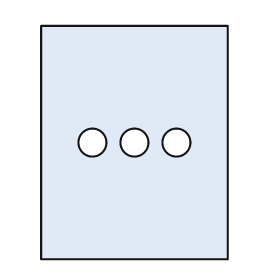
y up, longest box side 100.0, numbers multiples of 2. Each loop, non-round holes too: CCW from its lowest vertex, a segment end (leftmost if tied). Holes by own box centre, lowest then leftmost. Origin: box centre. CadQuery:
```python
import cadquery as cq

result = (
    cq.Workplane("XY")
    .moveTo(-40.0, -50.0)
    .lineTo(40.0, -50.0)
    .lineTo(40.0, 50.0)
    .lineTo(-40.0, 50.0)
    .close()
    .moveTo(-18.0, 0.0)
    .circle(6.0)
    .moveTo(0.0, 0.0)
    .circle(6.0)
    .moveTo(18.0, 0.0)
    .circle(6.0)
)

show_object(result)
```